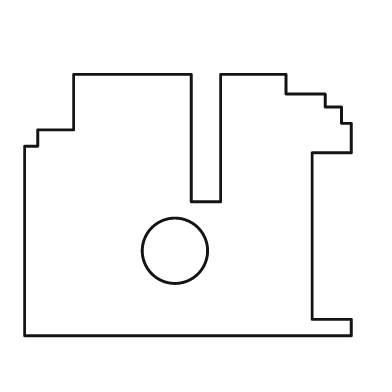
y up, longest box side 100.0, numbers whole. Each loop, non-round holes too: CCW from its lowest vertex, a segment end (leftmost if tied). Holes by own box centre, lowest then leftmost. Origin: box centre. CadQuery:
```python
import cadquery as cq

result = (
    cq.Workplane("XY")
    .moveTo(-50.0, -40.0)
    .lineTo(50.0, -40.0)
    .lineTo(50.0, -35.0)
    .lineTo(38.0, -35.0)
    .lineTo(38.0, 16.0)
    .lineTo(50.0, 16.0)
    .lineTo(50.0, 25.0)
    .lineTo(47.0, 25.0)
    .lineTo(47.0, 30.0)
    .lineTo(42.0, 30.0)
    .lineTo(42.0, 34.0)
    .lineTo(30.0, 34.0)
    .lineTo(30.0, 40.0)
    .lineTo(10.0, 40.0)
    .lineTo(10.0, 1.0)
    .lineTo(1.0, 1.0)
    .lineTo(1.0, 40.0)
    .lineTo(-35.0, 40.0)
    .lineTo(-35.0, 23.0)
    .lineTo(-46.0, 23.0)
    .lineTo(-46.0, 18.0)
    .lineTo(-50.0, 18.0)
    .close()
    .moveTo(-4.0, -14.0)
    .circle(10.0)
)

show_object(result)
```